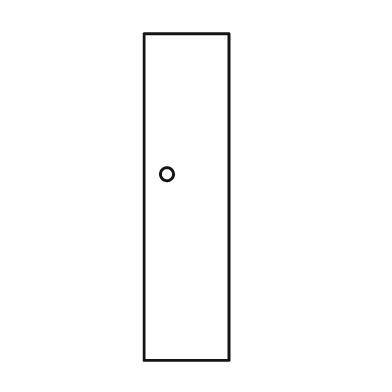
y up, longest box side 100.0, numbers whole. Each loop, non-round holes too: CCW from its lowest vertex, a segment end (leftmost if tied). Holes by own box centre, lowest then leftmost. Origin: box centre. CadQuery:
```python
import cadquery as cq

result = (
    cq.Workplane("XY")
    .moveTo(-13.0, -50.0)
    .lineTo(13.0, -50.0)
    .lineTo(13.0, 50.0)
    .lineTo(-13.0, 50.0)
    .close()
    .moveTo(-6.0, 7.0)
    .circle(2.0)
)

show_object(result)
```